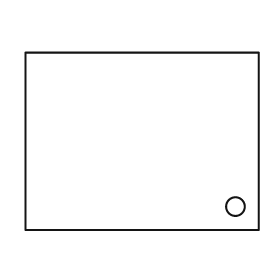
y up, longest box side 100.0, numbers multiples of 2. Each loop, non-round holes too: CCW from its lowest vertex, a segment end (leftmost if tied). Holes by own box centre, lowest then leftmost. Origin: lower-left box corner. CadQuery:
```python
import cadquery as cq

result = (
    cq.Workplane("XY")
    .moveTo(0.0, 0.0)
    .lineTo(100.0, 0.0)
    .lineTo(100.0, 76.0)
    .lineTo(0.0, 76.0)
    .close()
    .moveTo(90.0, 10.0)
    .circle(4.0)
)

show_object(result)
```